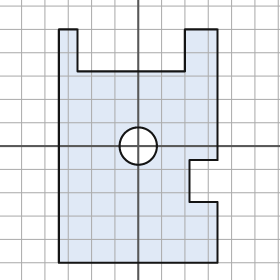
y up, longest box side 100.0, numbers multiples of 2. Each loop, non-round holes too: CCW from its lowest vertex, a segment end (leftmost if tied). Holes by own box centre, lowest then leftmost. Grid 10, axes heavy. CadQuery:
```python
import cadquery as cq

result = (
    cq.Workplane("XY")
    .moveTo(-34.0, -50.0)
    .lineTo(34.0, -50.0)
    .lineTo(34.0, -24.0)
    .lineTo(22.0, -24.0)
    .lineTo(22.0, -6.0)
    .lineTo(34.0, -6.0)
    .lineTo(34.0, 50.0)
    .lineTo(20.0, 50.0)
    .lineTo(20.0, 32.0)
    .lineTo(-26.0, 32.0)
    .lineTo(-26.0, 50.0)
    .lineTo(-34.0, 50.0)
    .close()
    .moveTo(0.0, 0.0)
    .circle(8.0)
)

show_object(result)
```